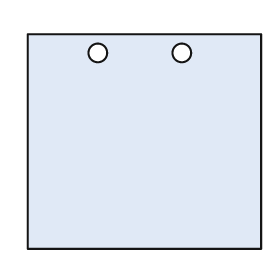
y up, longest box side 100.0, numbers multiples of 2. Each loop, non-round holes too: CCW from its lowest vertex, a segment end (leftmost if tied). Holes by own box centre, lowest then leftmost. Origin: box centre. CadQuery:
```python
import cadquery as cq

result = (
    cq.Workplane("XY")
    .moveTo(-50.0, -46.0)
    .lineTo(50.0, -46.0)
    .lineTo(50.0, 46.0)
    .lineTo(-50.0, 46.0)
    .close()
    .moveTo(-20.0, 38.0)
    .circle(4.0)
    .moveTo(16.0, 38.0)
    .circle(4.0)
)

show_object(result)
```